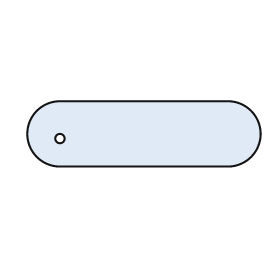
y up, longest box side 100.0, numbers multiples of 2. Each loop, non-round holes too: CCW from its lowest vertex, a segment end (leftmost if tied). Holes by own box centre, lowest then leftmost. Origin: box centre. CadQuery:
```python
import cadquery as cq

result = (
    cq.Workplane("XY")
    .moveTo(-36.0, -14.0)
    .lineTo(36.0, -14.0)
    .threePointArc((50.0, 0.0), (36.0, 14.0))
    .lineTo(-36.0, 14.0)
    .threePointArc((-50.0, 0.0), (-36.0, -14.0))
    .close()
    .moveTo(-36.0, -2.0)
    .circle(2.0)
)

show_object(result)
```